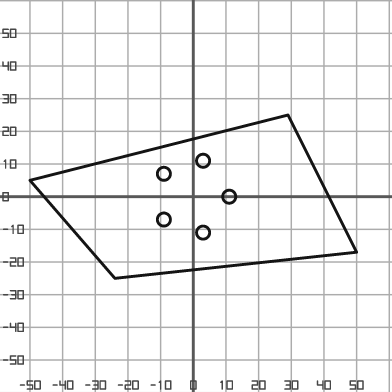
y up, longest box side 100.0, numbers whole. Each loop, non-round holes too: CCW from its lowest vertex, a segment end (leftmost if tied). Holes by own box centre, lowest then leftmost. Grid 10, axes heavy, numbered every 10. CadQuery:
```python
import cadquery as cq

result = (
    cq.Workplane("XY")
    .moveTo(-24.0, -25.0)
    .lineTo(50.0, -17.0)
    .lineTo(29.0, 25.0)
    .lineTo(-50.0, 5.0)
    .close()
    .moveTo(3.0, -11.0)
    .circle(2.0)
    .moveTo(-9.0, -7.0)
    .circle(2.0)
    .moveTo(11.0, 0.0)
    .circle(2.0)
    .moveTo(-9.0, 7.0)
    .circle(2.0)
    .moveTo(3.0, 11.0)
    .circle(2.0)
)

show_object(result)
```